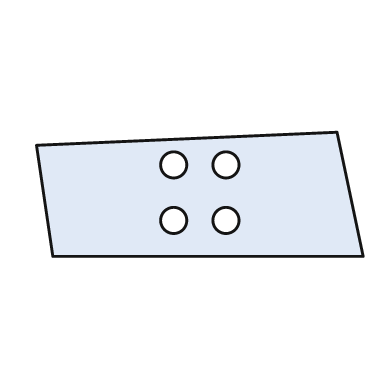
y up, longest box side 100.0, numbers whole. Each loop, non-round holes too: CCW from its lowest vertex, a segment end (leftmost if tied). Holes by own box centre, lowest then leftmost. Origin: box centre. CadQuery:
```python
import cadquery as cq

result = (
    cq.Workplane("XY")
    .moveTo(-45.0, -19.0)
    .lineTo(50.0, -19.0)
    .lineTo(42.0, 19.0)
    .lineTo(-50.0, 15.0)
    .close()
    .moveTo(-8.0, -8.0)
    .circle(4.0)
    .moveTo(8.0, -8.0)
    .circle(4.0)
    .moveTo(-8.0, 9.0)
    .circle(4.0)
    .moveTo(8.0, 9.0)
    .circle(4.0)
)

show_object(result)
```